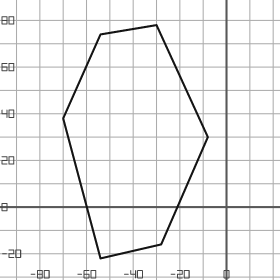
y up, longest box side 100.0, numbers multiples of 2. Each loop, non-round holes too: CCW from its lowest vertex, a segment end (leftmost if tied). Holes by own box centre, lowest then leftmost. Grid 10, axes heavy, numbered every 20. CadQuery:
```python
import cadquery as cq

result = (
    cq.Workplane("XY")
    .moveTo(-54.0, -22.0)
    .lineTo(-28.0, -16.0)
    .lineTo(-8.0, 30.0)
    .lineTo(-30.0, 78.0)
    .lineTo(-54.0, 74.0)
    .lineTo(-70.0, 38.0)
    .close()
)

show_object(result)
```